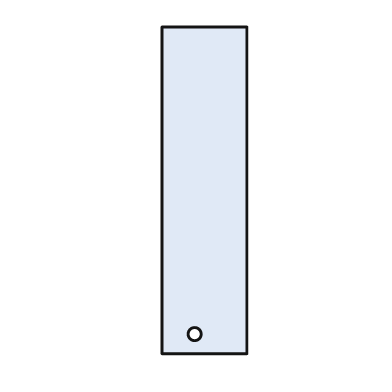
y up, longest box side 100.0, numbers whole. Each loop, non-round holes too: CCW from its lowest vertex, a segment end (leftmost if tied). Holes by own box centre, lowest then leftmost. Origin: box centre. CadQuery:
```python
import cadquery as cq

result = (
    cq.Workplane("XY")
    .moveTo(-13.0, -50.0)
    .lineTo(13.0, -50.0)
    .lineTo(13.0, 50.0)
    .lineTo(-13.0, 50.0)
    .close()
    .moveTo(-3.0, -44.0)
    .circle(2.0)
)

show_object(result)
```